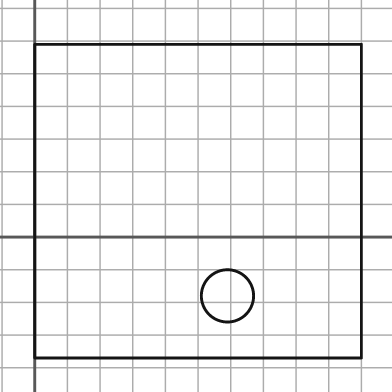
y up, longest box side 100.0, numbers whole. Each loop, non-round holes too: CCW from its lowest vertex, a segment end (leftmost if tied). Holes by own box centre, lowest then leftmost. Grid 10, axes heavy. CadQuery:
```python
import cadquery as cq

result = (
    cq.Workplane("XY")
    .moveTo(0.0, -37.0)
    .lineTo(100.0, -37.0)
    .lineTo(100.0, 59.0)
    .lineTo(0.0, 59.0)
    .close()
    .moveTo(59.0, -18.0)
    .circle(8.0)
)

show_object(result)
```